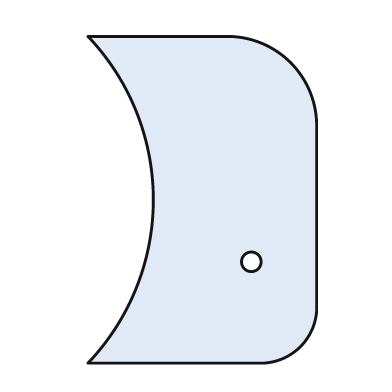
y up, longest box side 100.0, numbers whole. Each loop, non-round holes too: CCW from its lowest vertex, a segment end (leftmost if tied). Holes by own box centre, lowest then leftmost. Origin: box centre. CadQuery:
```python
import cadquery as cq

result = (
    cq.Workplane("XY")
    .moveTo(-35.0, -50.0)
    .lineTo(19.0, -50.0)
    .threePointArc((30.0, -45.0), (35.0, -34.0))
    .lineTo(35.0, 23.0)
    .threePointArc((27.0, 42.0), (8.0, 50.0))
    .lineTo(-35.0, 50.0)
    .threePointArc((-15.0, 0.0), (-35.0, -50.0))
    .close()
    .moveTo(15.0, -19.0)
    .circle(3.0)
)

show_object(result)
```